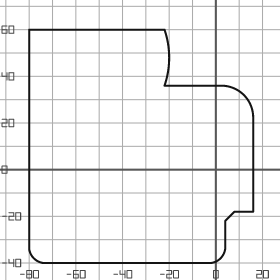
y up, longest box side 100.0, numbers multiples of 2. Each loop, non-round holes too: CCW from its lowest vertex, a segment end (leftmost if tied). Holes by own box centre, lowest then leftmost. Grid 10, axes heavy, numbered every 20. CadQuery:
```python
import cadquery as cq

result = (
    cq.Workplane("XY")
    .moveTo(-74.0, -40.0)
    .lineTo(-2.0, -40.0)
    .threePointArc((2.0, -38.0), (4.0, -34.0))
    .lineTo(4.0, -22.0)
    .lineTo(8.0, -18.0)
    .lineTo(16.0, -18.0)
    .lineTo(16.0, 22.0)
    .threePointArc((12.0, 32.0), (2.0, 36.0))
    .lineTo(-22.0, 36.0)
    .threePointArc((-20.0, 48.0), (-22.0, 60.0))
    .lineTo(-80.0, 60.0)
    .lineTo(-80.0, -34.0)
    .threePointArc((-78.0, -38.0), (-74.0, -40.0))
    .close()
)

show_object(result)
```